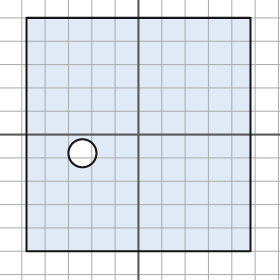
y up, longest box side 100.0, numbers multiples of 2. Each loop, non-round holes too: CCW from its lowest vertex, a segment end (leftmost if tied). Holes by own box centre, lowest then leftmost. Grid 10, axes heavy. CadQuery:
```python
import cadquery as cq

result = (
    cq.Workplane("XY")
    .moveTo(-48.0, -50.0)
    .lineTo(48.0, -50.0)
    .lineTo(48.0, 50.0)
    .lineTo(-48.0, 50.0)
    .close()
    .moveTo(-24.0, -8.0)
    .circle(6.0)
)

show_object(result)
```